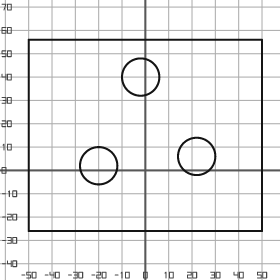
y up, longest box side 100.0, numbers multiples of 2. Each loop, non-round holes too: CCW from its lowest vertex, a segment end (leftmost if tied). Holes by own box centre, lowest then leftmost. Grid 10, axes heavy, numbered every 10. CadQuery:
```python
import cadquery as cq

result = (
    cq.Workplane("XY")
    .moveTo(-50.0, -26.0)
    .lineTo(50.0, -26.0)
    .lineTo(50.0, 56.0)
    .lineTo(-50.0, 56.0)
    .close()
    .moveTo(-20.0, 2.0)
    .circle(8.0)
    .moveTo(22.0, 6.0)
    .circle(8.0)
    .moveTo(-2.0, 40.0)
    .circle(8.0)
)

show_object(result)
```